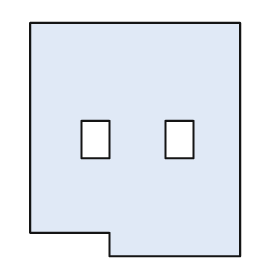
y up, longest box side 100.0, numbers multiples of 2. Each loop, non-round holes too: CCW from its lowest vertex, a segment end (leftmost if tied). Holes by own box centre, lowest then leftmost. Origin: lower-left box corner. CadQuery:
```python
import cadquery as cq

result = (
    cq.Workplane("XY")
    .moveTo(34.0, 0.0)
    .lineTo(90.0, 0.0)
    .lineTo(90.0, 100.0)
    .lineTo(0.0, 100.0)
    .lineTo(0.0, 10.0)
    .lineTo(34.0, 10.0)
    .close()
    .moveTo(22.0, 42.0)
    .lineTo(34.0, 42.0)
    .lineTo(34.0, 58.0)
    .lineTo(22.0, 58.0)
    .close()
    .moveTo(58.0, 42.0)
    .lineTo(70.0, 42.0)
    .lineTo(70.0, 58.0)
    .lineTo(58.0, 58.0)
    .close()
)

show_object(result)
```